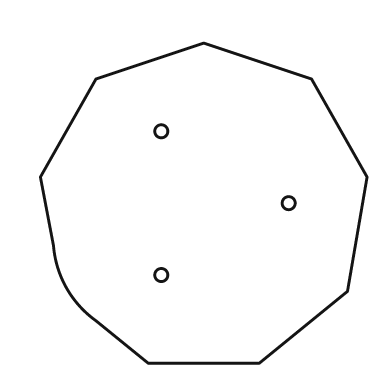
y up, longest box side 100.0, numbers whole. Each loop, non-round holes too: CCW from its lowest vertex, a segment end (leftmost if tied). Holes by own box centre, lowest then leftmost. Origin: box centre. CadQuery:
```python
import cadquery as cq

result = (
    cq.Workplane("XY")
    .moveTo(-17.0, -49.0)
    .lineTo(17.0, -49.0)
    .lineTo(44.0, -27.0)
    .lineTo(50.0, 8.0)
    .lineTo(33.0, 38.0)
    .lineTo(0.0, 49.0)
    .lineTo(-33.0, 38.0)
    .lineTo(-50.0, 8.0)
    .lineTo(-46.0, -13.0)
    .threePointArc((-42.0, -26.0), (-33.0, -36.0))
    .close()
    .moveTo(-13.0, -22.0)
    .circle(2.0)
    .moveTo(26.0, 0.0)
    .circle(2.0)
    .moveTo(-13.0, 22.0)
    .circle(2.0)
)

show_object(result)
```